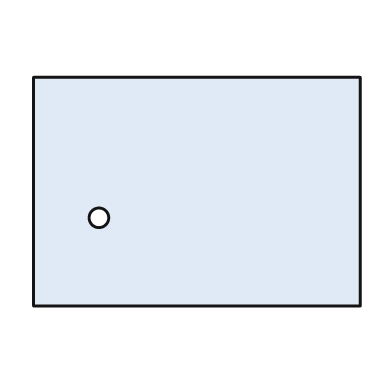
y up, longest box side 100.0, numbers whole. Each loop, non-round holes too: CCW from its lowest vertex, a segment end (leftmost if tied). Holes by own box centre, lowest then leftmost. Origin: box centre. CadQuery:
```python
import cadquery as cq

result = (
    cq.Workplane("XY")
    .moveTo(-50.0, -35.0)
    .lineTo(50.0, -35.0)
    .lineTo(50.0, 35.0)
    .lineTo(-50.0, 35.0)
    .close()
    .moveTo(-30.0, -8.0)
    .circle(3.0)
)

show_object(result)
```